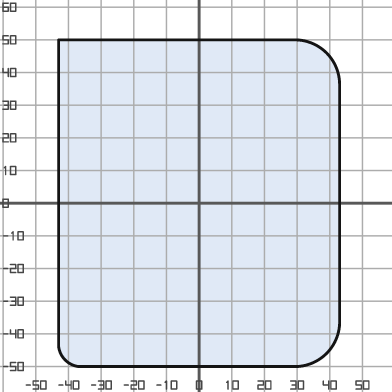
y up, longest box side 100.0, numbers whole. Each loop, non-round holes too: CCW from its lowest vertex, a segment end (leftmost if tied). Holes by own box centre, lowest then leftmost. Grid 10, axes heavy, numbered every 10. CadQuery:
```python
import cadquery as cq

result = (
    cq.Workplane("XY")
    .moveTo(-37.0, -50.0)
    .lineTo(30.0, -50.0)
    .threePointArc((39.0, -46.0), (43.0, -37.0))
    .lineTo(43.0, 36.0)
    .threePointArc((39.0, 46.0), (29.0, 50.0))
    .lineTo(-43.0, 50.0)
    .lineTo(-43.0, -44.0)
    .threePointArc((-41.0, -48.0), (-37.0, -50.0))
    .close()
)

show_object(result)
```